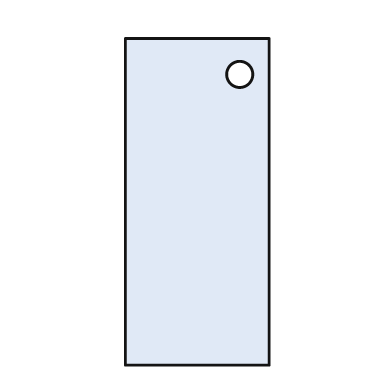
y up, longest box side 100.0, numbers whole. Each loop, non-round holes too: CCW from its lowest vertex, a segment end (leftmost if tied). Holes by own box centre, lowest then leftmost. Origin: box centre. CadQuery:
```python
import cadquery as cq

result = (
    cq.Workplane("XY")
    .moveTo(-22.0, -50.0)
    .lineTo(22.0, -50.0)
    .lineTo(22.0, 50.0)
    .lineTo(-22.0, 50.0)
    .close()
    .moveTo(13.0, 39.0)
    .circle(4.0)
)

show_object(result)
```